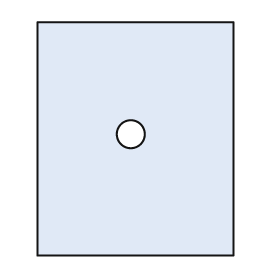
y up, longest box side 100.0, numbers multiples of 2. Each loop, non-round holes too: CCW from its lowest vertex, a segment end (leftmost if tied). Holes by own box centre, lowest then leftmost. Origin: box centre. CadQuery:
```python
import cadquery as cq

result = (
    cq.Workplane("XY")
    .moveTo(-42.0, -50.0)
    .lineTo(42.0, -50.0)
    .lineTo(42.0, 50.0)
    .lineTo(-42.0, 50.0)
    .close()
    .moveTo(-2.0, 2.0)
    .circle(6.0)
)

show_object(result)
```